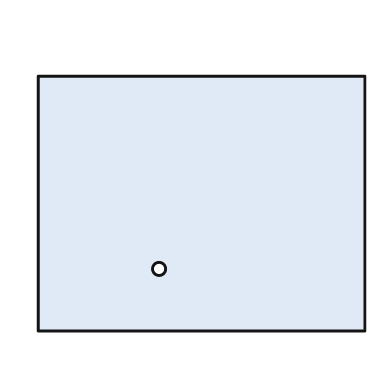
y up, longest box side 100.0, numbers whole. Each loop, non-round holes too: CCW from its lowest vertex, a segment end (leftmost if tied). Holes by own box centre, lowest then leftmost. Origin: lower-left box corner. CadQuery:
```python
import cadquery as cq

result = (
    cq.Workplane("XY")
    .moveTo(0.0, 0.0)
    .lineTo(100.0, 0.0)
    .lineTo(100.0, 78.0)
    .lineTo(0.0, 78.0)
    .close()
    .moveTo(37.0, 19.0)
    .circle(2.0)
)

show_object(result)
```